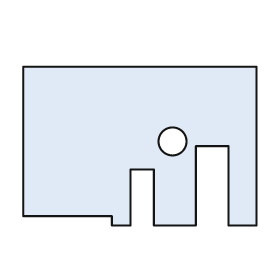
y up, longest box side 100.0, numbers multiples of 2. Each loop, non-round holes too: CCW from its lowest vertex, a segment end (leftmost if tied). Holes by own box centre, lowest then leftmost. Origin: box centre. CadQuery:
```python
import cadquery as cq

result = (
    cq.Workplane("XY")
    .moveTo(-12.0, -34.0)
    .lineTo(-4.0, -34.0)
    .lineTo(-4.0, -10.0)
    .lineTo(6.0, -10.0)
    .lineTo(6.0, -34.0)
    .lineTo(24.0, -34.0)
    .lineTo(24.0, 0.0)
    .lineTo(38.0, 0.0)
    .lineTo(38.0, -34.0)
    .lineTo(50.0, -34.0)
    .lineTo(50.0, 34.0)
    .lineTo(-50.0, 34.0)
    .lineTo(-50.0, -30.0)
    .lineTo(-12.0, -30.0)
    .close()
    .moveTo(14.0, 2.0)
    .circle(6.0)
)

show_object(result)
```